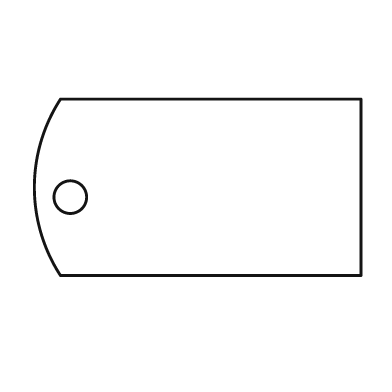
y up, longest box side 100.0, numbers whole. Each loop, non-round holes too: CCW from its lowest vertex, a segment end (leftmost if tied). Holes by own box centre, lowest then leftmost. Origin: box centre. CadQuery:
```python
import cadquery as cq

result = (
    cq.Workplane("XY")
    .moveTo(-42.0, -27.0)
    .lineTo(50.0, -27.0)
    .lineTo(50.0, 27.0)
    .lineTo(-42.0, 27.0)
    .threePointArc((-50.0, 0.0), (-42.0, -27.0))
    .close()
    .moveTo(-39.0, -3.0)
    .circle(5.0)
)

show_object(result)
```